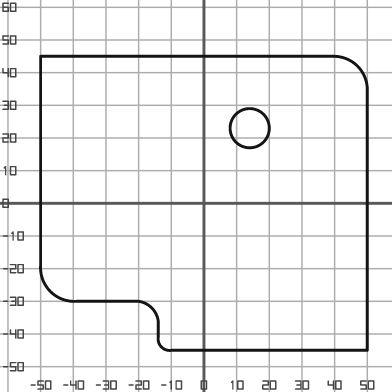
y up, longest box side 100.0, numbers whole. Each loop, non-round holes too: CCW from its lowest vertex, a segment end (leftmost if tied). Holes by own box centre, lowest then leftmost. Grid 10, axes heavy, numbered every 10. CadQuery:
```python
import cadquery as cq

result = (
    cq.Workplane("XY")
    .moveTo(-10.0, -45.0)
    .lineTo(50.0, -45.0)
    .lineTo(50.0, 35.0)
    .threePointArc((47.0, 42.0), (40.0, 45.0))
    .lineTo(-50.0, 45.0)
    .lineTo(-50.0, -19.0)
    .threePointArc((-47.0, -27.0), (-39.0, -30.0))
    .lineTo(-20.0, -30.0)
    .threePointArc((-16.0, -32.0), (-14.0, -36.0))
    .lineTo(-14.0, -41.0)
    .threePointArc((-13.0, -44.0), (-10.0, -45.0))
    .close()
    .moveTo(14.0, 23.0)
    .circle(6.0)
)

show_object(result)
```